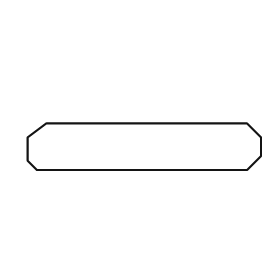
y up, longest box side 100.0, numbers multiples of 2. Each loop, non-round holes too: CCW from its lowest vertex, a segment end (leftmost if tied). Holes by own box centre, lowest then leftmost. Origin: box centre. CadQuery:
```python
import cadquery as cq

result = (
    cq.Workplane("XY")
    .moveTo(-46.0, -10.0)
    .lineTo(44.0, -10.0)
    .lineTo(50.0, -4.0)
    .lineTo(50.0, 4.0)
    .lineTo(44.0, 10.0)
    .lineTo(-42.0, 10.0)
    .lineTo(-50.0, 4.0)
    .lineTo(-50.0, -6.0)
    .close()
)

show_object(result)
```